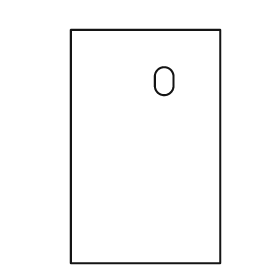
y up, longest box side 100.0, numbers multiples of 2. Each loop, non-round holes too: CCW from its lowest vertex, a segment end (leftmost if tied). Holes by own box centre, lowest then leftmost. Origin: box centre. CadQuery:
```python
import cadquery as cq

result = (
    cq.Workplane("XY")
    .moveTo(-32.0, -50.0)
    .lineTo(32.0, -50.0)
    .lineTo(32.0, 50.0)
    .lineTo(-32.0, 50.0)
    .close()
    .moveTo(4.0, 26.0)
    .threePointArc((8.0, 22.0), (12.0, 26.0))
    .lineTo(12.0, 30.0)
    .threePointArc((8.0, 34.0), (4.0, 30.0))
    .close()
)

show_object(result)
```